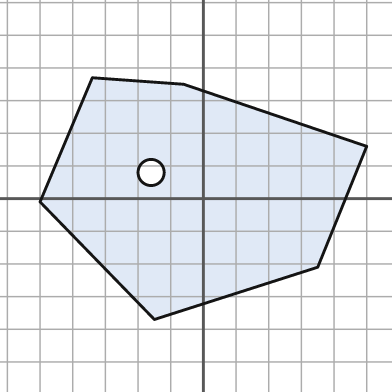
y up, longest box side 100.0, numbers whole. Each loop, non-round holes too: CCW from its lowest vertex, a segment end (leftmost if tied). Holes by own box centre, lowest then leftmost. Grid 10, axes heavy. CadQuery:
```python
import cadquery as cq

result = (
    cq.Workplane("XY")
    .moveTo(-15.0, -37.0)
    .lineTo(35.0, -21.0)
    .lineTo(50.0, 16.0)
    .lineTo(-6.0, 35.0)
    .lineTo(-34.0, 37.0)
    .lineTo(-50.0, -1.0)
    .close()
    .moveTo(-16.0, 8.0)
    .circle(4.0)
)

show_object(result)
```